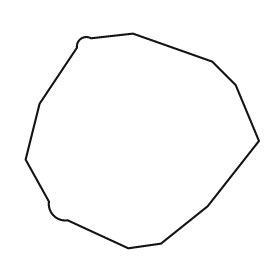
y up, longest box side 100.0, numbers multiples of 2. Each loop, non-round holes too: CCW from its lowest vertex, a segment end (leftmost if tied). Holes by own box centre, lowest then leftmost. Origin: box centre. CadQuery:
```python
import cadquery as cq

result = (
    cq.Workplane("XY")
    .moveTo(-6.0, -46.0)
    .lineTo(8.0, -44.0)
    .lineTo(28.0, -28.0)
    .lineTo(50.0, 0.0)
    .lineTo(40.0, 24.0)
    .lineTo(30.0, 34.0)
    .lineTo(-4.0, 46.0)
    .lineTo(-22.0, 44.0)
    .threePointArc((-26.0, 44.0), (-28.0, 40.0))
    .lineTo(-44.0, 16.0)
    .lineTo(-50.0, -8.0)
    .lineTo(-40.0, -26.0)
    .threePointArc((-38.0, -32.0), (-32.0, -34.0))
    .close()
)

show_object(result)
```